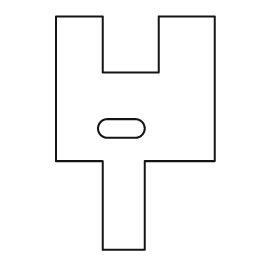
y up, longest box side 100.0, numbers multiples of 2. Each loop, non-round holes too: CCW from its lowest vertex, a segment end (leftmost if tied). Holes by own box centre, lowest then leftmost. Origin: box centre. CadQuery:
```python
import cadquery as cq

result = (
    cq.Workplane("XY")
    .moveTo(-14.0, -50.0)
    .lineTo(4.0, -50.0)
    .lineTo(4.0, -12.0)
    .lineTo(34.0, -12.0)
    .lineTo(34.0, 50.0)
    .lineTo(10.0, 50.0)
    .lineTo(10.0, 26.0)
    .lineTo(-14.0, 26.0)
    .lineTo(-14.0, 50.0)
    .lineTo(-34.0, 50.0)
    .lineTo(-34.0, -12.0)
    .lineTo(-14.0, -12.0)
    .close()
    .moveTo(-12.0, -2.0)
    .lineTo(0.0, -2.0)
    .threePointArc((4.0, 2.0), (0.0, 6.0))
    .lineTo(-12.0, 6.0)
    .threePointArc((-16.0, 2.0), (-12.0, -2.0))
    .close()
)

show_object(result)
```